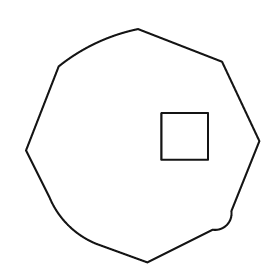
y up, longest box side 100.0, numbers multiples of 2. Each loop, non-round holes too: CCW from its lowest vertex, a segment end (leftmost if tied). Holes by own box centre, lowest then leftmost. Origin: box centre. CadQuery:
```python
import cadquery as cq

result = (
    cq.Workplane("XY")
    .moveTo(2.0, -50.0)
    .lineTo(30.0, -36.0)
    .threePointArc((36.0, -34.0), (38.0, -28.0))
    .lineTo(50.0, 2.0)
    .lineTo(34.0, 36.0)
    .lineTo(-2.0, 50.0)
    .threePointArc((-20.0, 44.0), (-36.0, 34.0))
    .lineTo(-50.0, -2.0)
    .lineTo(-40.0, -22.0)
    .threePointArc((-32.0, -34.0), (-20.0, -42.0))
    .close()
    .moveTo(8.0, -6.0)
    .lineTo(28.0, -6.0)
    .lineTo(28.0, 14.0)
    .lineTo(8.0, 14.0)
    .close()
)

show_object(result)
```